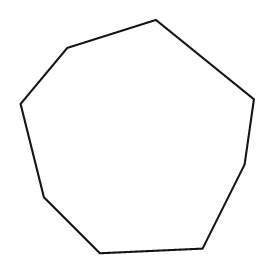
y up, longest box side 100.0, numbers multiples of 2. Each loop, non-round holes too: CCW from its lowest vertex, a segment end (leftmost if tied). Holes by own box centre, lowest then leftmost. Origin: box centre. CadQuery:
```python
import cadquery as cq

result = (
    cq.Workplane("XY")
    .moveTo(-16.0, -50.0)
    .lineTo(28.0, -48.0)
    .lineTo(46.0, -12.0)
    .lineTo(50.0, 16.0)
    .lineTo(8.0, 50.0)
    .lineTo(-30.0, 38.0)
    .lineTo(-50.0, 14.0)
    .lineTo(-40.0, -26.0)
    .close()
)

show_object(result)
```